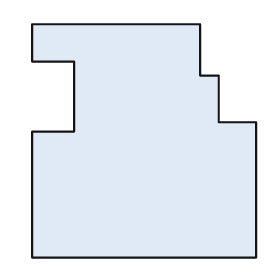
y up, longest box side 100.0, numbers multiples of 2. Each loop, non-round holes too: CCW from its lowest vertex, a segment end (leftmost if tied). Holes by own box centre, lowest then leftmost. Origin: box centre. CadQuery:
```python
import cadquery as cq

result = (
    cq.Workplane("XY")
    .moveTo(-48.0, -50.0)
    .lineTo(48.0, -50.0)
    .lineTo(48.0, 8.0)
    .lineTo(32.0, 8.0)
    .lineTo(32.0, 28.0)
    .lineTo(24.0, 28.0)
    .lineTo(24.0, 50.0)
    .lineTo(-48.0, 50.0)
    .lineTo(-48.0, 34.0)
    .lineTo(-30.0, 34.0)
    .lineTo(-30.0, 4.0)
    .lineTo(-48.0, 4.0)
    .close()
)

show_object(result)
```